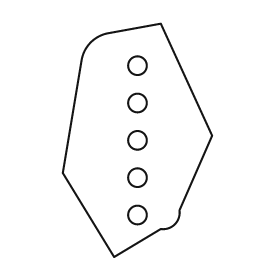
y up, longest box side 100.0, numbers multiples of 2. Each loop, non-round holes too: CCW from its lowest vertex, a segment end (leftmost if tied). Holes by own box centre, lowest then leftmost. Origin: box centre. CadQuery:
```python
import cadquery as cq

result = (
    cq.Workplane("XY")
    .moveTo(-10.0, -50.0)
    .lineTo(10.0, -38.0)
    .threePointArc((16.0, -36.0), (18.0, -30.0))
    .lineTo(32.0, 2.0)
    .lineTo(10.0, 50.0)
    .lineTo(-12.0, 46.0)
    .threePointArc((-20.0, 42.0), (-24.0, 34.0))
    .lineTo(-32.0, -14.0)
    .close()
    .moveTo(0.0, -32.0)
    .circle(4.0)
    .moveTo(0.0, -16.0)
    .circle(4.0)
    .moveTo(0.0, 0.0)
    .circle(4.0)
    .moveTo(0.0, 16.0)
    .circle(4.0)
    .moveTo(0.0, 32.0)
    .circle(4.0)
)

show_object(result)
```